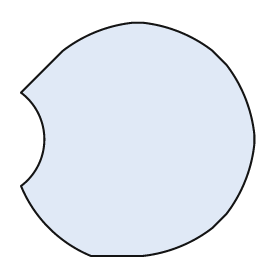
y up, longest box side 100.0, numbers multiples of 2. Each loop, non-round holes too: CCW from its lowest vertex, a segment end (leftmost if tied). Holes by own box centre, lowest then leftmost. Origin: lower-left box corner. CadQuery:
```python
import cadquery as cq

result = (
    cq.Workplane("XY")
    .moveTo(30.0, 0.0)
    .lineTo(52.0, 0.0)
    .threePointArc((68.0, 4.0), (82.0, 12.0))
    .lineTo(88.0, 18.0)
    .threePointArc((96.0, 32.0), (100.0, 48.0))
    .lineTo(100.0, 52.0)
    .threePointArc((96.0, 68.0), (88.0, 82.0))
    .lineTo(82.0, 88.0)
    .threePointArc((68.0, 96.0), (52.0, 100.0))
    .lineTo(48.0, 100.0)
    .threePointArc((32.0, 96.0), (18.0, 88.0))
    .lineTo(0.0, 70.0)
    .threePointArc((10.0, 50.0), (0.0, 30.0))
    .threePointArc((12.0, 12.0), (30.0, 0.0))
    .close()
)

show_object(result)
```